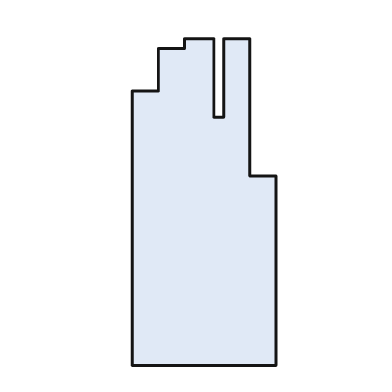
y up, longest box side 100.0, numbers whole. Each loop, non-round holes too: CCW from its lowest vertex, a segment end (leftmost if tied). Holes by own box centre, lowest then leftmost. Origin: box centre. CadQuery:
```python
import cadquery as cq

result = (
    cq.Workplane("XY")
    .moveTo(-22.0, -50.0)
    .lineTo(22.0, -50.0)
    .lineTo(22.0, 8.0)
    .lineTo(14.0, 8.0)
    .lineTo(14.0, 50.0)
    .lineTo(6.0, 50.0)
    .lineTo(6.0, 26.0)
    .lineTo(3.0, 26.0)
    .lineTo(3.0, 50.0)
    .lineTo(-6.0, 50.0)
    .lineTo(-6.0, 47.0)
    .lineTo(-14.0, 47.0)
    .lineTo(-14.0, 34.0)
    .lineTo(-22.0, 34.0)
    .close()
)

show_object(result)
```